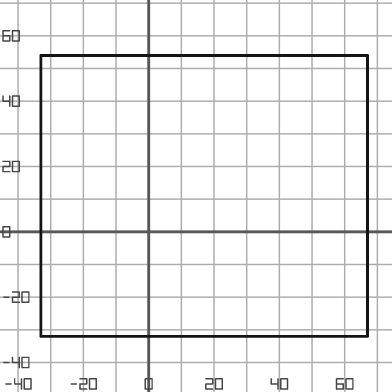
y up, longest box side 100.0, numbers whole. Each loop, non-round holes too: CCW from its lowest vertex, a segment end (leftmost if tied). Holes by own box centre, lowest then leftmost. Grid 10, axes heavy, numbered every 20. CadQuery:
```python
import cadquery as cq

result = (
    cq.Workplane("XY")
    .moveTo(-33.0, -32.0)
    .lineTo(67.0, -32.0)
    .lineTo(67.0, 54.0)
    .lineTo(-33.0, 54.0)
    .close()
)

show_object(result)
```